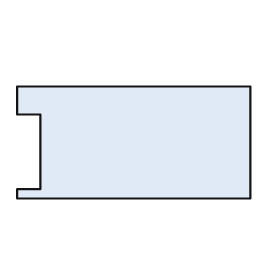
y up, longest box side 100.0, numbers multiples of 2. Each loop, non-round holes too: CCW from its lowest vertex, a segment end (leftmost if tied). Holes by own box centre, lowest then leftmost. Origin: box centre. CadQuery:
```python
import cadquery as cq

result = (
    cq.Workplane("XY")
    .moveTo(-50.0, -24.0)
    .lineTo(50.0, -24.0)
    .lineTo(50.0, 24.0)
    .lineTo(-50.0, 24.0)
    .lineTo(-50.0, 12.0)
    .lineTo(-40.0, 12.0)
    .lineTo(-40.0, -20.0)
    .lineTo(-50.0, -20.0)
    .close()
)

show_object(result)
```